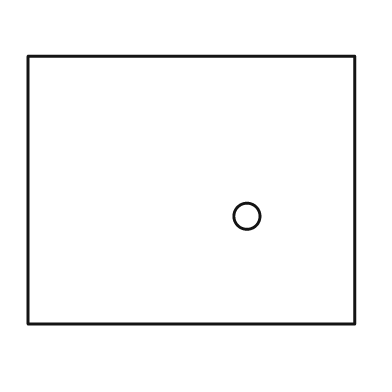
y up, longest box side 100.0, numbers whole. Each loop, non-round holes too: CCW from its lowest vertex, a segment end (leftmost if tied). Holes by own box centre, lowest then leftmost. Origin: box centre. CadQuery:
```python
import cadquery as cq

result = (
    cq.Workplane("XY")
    .moveTo(-50.0, -41.0)
    .lineTo(50.0, -41.0)
    .lineTo(50.0, 41.0)
    .lineTo(-50.0, 41.0)
    .close()
    .moveTo(17.0, -8.0)
    .circle(4.0)
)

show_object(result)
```